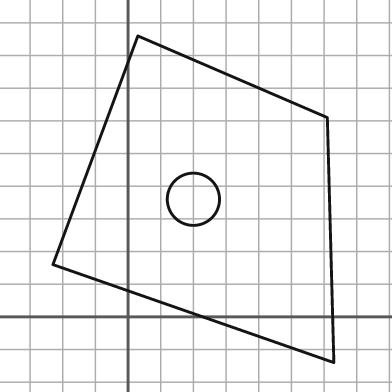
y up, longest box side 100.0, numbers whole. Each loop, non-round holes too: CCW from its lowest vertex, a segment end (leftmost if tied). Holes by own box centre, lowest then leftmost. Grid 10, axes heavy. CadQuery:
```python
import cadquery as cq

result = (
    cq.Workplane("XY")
    .moveTo(63.0, -14.0)
    .lineTo(61.0, 61.0)
    .lineTo(3.0, 86.0)
    .lineTo(-23.0, 16.0)
    .close()
    .moveTo(20.0, 36.0)
    .circle(8.0)
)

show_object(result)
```